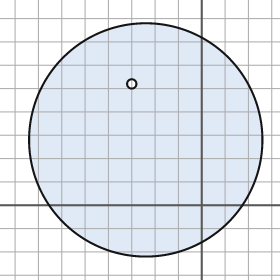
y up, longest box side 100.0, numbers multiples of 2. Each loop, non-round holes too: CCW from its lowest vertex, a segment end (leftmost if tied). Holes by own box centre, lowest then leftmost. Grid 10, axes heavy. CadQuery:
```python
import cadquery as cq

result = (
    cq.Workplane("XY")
    .moveTo(-24.0, 28.0)
    .circle(50.0)
    .moveTo(-30.0, 52.0)
    .circle(2.0)
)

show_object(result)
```